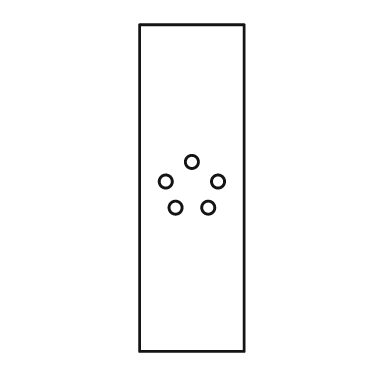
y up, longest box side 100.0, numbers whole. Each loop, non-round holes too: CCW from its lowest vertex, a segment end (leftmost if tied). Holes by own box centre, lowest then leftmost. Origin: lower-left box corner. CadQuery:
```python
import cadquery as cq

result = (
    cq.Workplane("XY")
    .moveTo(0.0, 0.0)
    .lineTo(32.0, 0.0)
    .lineTo(32.0, 100.0)
    .lineTo(0.0, 100.0)
    .close()
    .moveTo(11.0, 44.0)
    .circle(2.0)
    .moveTo(21.0, 44.0)
    .circle(2.0)
    .moveTo(8.0, 52.0)
    .circle(2.0)
    .moveTo(24.0, 52.0)
    .circle(2.0)
    .moveTo(16.0, 58.0)
    .circle(2.0)
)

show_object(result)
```